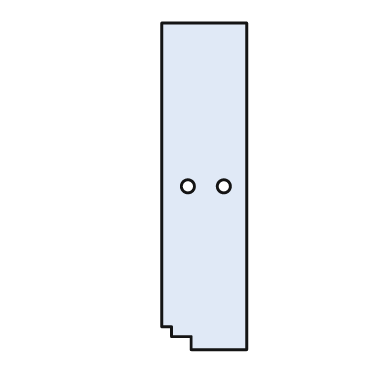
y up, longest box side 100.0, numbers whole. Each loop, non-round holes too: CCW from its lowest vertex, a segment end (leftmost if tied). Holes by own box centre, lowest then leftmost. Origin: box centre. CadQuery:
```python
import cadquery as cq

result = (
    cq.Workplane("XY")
    .moveTo(-4.0, -50.0)
    .lineTo(13.0, -50.0)
    .lineTo(13.0, 50.0)
    .lineTo(-13.0, 50.0)
    .lineTo(-13.0, -43.0)
    .lineTo(-10.0, -43.0)
    .lineTo(-10.0, -46.0)
    .lineTo(-4.0, -46.0)
    .close()
    .moveTo(-5.0, 0.0)
    .circle(2.0)
    .moveTo(6.0, 0.0)
    .circle(2.0)
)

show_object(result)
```